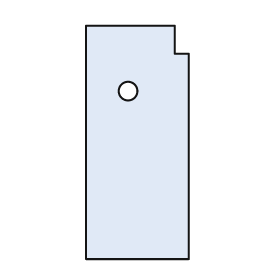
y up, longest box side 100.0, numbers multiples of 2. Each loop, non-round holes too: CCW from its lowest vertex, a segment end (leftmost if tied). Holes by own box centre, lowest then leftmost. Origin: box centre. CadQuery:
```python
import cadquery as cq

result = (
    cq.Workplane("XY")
    .moveTo(-22.0, -50.0)
    .lineTo(22.0, -50.0)
    .lineTo(22.0, 38.0)
    .lineTo(16.0, 38.0)
    .lineTo(16.0, 50.0)
    .lineTo(-22.0, 50.0)
    .close()
    .moveTo(-4.0, 22.0)
    .circle(4.0)
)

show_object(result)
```